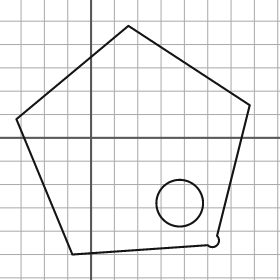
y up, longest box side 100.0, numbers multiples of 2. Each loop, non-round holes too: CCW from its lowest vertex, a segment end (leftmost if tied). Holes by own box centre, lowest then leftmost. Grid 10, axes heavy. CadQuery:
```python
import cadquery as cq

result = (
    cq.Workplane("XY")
    .moveTo(-8.0, -50.0)
    .lineTo(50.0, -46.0)
    .threePointArc((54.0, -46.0), (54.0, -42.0))
    .lineTo(68.0, 14.0)
    .lineTo(16.0, 48.0)
    .lineTo(-32.0, 8.0)
    .close()
    .moveTo(38.0, -28.0)
    .circle(10.0)
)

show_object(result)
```